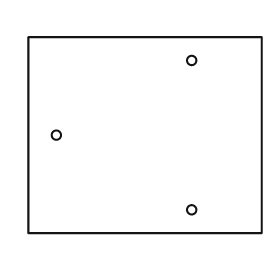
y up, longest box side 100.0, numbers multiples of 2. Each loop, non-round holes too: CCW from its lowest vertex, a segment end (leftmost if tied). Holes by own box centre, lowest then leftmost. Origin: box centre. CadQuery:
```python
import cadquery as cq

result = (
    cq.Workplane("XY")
    .moveTo(-50.0, -42.0)
    .lineTo(50.0, -42.0)
    .lineTo(50.0, 42.0)
    .lineTo(-50.0, 42.0)
    .close()
    .moveTo(20.0, -32.0)
    .circle(2.0)
    .moveTo(-38.0, 0.0)
    .circle(2.0)
    .moveTo(20.0, 32.0)
    .circle(2.0)
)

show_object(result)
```